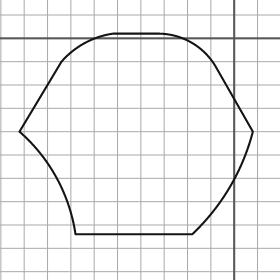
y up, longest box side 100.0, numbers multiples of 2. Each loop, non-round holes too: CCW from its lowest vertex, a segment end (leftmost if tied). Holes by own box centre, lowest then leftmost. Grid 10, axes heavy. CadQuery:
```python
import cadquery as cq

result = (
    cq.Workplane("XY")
    .moveTo(-68.0, -84.0)
    .lineTo(-18.0, -84.0)
    .threePointArc((-2.0, -64.0), (8.0, -40.0))
    .lineTo(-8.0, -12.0)
    .threePointArc((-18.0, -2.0), (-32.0, 2.0))
    .lineTo(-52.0, 2.0)
    .threePointArc((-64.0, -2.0), (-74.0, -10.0))
    .lineTo(-92.0, -40.0)
    .threePointArc((-76.0, -60.0), (-68.0, -84.0))
    .close()
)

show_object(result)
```